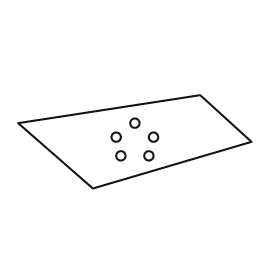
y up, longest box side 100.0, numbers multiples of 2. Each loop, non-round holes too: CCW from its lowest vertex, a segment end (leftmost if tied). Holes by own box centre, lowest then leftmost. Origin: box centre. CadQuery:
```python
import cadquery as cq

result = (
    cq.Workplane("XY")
    .moveTo(-18.0, -20.0)
    .lineTo(50.0, 0.0)
    .lineTo(28.0, 20.0)
    .lineTo(-50.0, 8.0)
    .close()
    .moveTo(-6.0, -6.0)
    .circle(2.0)
    .moveTo(6.0, -6.0)
    .circle(2.0)
    .moveTo(-8.0, 2.0)
    .circle(2.0)
    .moveTo(8.0, 2.0)
    .circle(2.0)
    .moveTo(0.0, 8.0)
    .circle(2.0)
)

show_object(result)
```